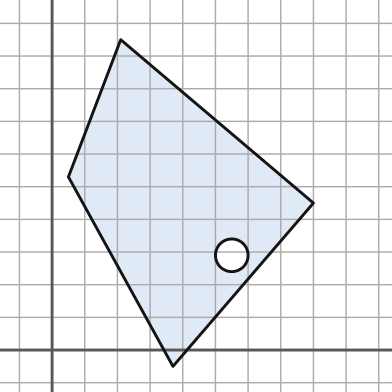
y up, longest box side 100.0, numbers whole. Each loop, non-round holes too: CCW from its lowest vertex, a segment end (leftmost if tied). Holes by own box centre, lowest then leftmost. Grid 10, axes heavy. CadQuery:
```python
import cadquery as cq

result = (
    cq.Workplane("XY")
    .moveTo(37.0, -5.0)
    .lineTo(80.0, 45.0)
    .lineTo(21.0, 95.0)
    .lineTo(5.0, 53.0)
    .close()
    .moveTo(55.0, 29.0)
    .circle(5.0)
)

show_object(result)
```